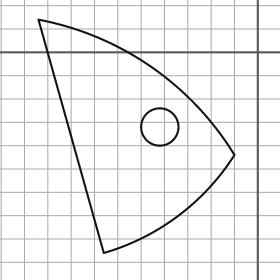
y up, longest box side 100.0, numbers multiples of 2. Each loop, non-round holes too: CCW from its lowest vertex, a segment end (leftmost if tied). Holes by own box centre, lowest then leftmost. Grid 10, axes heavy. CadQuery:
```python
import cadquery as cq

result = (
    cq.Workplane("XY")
    .moveTo(-66.0, -86.0)
    .threePointArc((-34.0, -70.0), (-10.0, -44.0))
    .threePointArc((-46.0, -6.0), (-94.0, 14.0))
    .close()
    .moveTo(-42.0, -32.0)
    .circle(8.0)
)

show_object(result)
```